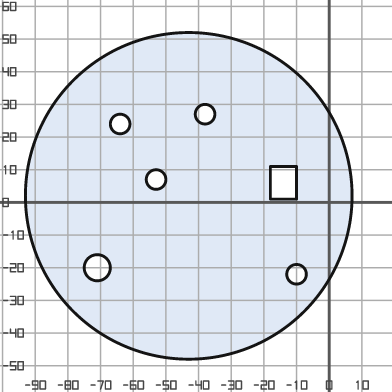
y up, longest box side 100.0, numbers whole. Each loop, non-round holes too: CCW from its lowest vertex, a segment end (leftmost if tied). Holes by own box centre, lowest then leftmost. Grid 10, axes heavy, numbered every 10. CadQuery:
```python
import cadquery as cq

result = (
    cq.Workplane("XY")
    .moveTo(-43.0, 2.0)
    .circle(50.0)
    .moveTo(-10.0, -22.0)
    .circle(3.0)
    .moveTo(-71.0, -20.0)
    .circle(4.0)
    .moveTo(-18.0, 1.0)
    .lineTo(-10.0, 1.0)
    .lineTo(-10.0, 11.0)
    .lineTo(-18.0, 11.0)
    .close()
    .moveTo(-53.0, 7.0)
    .circle(3.0)
    .moveTo(-64.0, 24.0)
    .circle(3.0)
    .moveTo(-38.0, 27.0)
    .circle(3.0)
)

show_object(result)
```